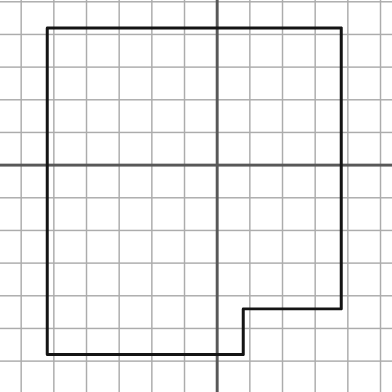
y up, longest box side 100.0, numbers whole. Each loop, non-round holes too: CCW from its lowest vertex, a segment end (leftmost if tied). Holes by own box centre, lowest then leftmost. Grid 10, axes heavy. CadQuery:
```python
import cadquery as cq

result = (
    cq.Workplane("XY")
    .moveTo(-52.0, -58.0)
    .lineTo(8.0, -58.0)
    .lineTo(8.0, -44.0)
    .lineTo(38.0, -44.0)
    .lineTo(38.0, 42.0)
    .lineTo(-52.0, 42.0)
    .close()
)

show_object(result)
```